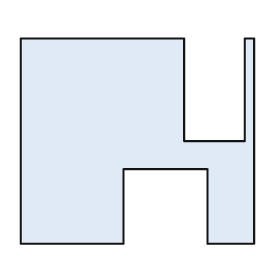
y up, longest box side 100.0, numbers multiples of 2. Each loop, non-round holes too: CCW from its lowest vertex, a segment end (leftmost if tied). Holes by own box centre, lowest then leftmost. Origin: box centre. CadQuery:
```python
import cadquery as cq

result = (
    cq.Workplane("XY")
    .moveTo(-50.0, -44.0)
    .lineTo(-6.0, -44.0)
    .lineTo(-6.0, -12.0)
    .lineTo(30.0, -12.0)
    .lineTo(30.0, -44.0)
    .lineTo(50.0, -44.0)
    .lineTo(50.0, 44.0)
    .lineTo(46.0, 44.0)
    .lineTo(46.0, 0.0)
    .lineTo(20.0, 0.0)
    .lineTo(20.0, 44.0)
    .lineTo(-50.0, 44.0)
    .close()
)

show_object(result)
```